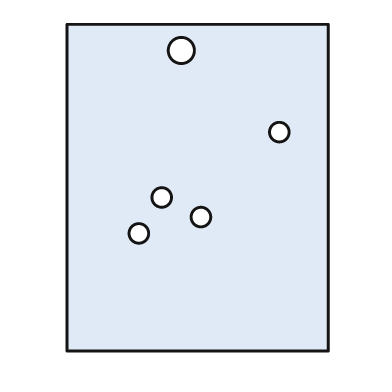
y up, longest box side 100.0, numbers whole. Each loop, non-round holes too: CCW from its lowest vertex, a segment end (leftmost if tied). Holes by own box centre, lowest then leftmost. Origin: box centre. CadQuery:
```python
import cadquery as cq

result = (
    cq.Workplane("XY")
    .moveTo(-40.0, -50.0)
    .lineTo(40.0, -50.0)
    .lineTo(40.0, 50.0)
    .lineTo(-40.0, 50.0)
    .close()
    .moveTo(-18.0, -14.0)
    .circle(3.0)
    .moveTo(1.0, -9.0)
    .circle(3.0)
    .moveTo(-11.0, -3.0)
    .circle(3.0)
    .moveTo(25.0, 17.0)
    .circle(3.0)
    .moveTo(-5.0, 42.0)
    .circle(4.0)
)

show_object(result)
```